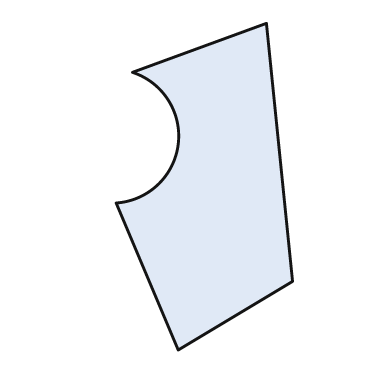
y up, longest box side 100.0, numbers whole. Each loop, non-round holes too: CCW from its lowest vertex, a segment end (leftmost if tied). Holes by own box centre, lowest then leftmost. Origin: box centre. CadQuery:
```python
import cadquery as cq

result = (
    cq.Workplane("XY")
    .moveTo(-8.0, -50.0)
    .lineTo(27.0, -29.0)
    .lineTo(19.0, 50.0)
    .lineTo(-22.0, 35.0)
    .threePointArc((-8.0, 13.0), (-27.0, -5.0))
    .close()
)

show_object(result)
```